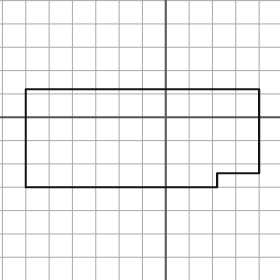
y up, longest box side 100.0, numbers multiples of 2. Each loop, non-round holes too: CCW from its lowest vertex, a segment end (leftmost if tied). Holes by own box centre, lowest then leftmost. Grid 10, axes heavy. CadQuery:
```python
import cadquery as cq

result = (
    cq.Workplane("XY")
    .moveTo(-60.0, -30.0)
    .lineTo(22.0, -30.0)
    .lineTo(22.0, -24.0)
    .lineTo(40.0, -24.0)
    .lineTo(40.0, 12.0)
    .lineTo(-60.0, 12.0)
    .close()
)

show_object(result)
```